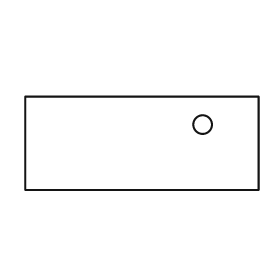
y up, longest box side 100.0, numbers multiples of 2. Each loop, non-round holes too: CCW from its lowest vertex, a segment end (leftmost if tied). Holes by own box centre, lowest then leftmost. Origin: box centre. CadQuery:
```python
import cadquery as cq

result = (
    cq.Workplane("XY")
    .moveTo(-50.0, -20.0)
    .lineTo(50.0, -20.0)
    .lineTo(50.0, 20.0)
    .lineTo(-50.0, 20.0)
    .close()
    .moveTo(26.0, 8.0)
    .circle(4.0)
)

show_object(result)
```